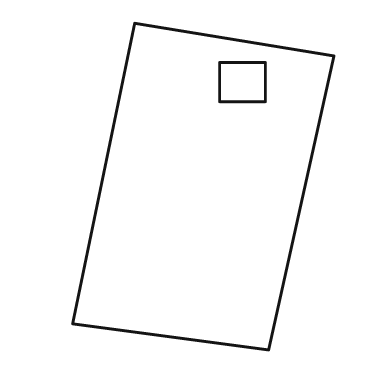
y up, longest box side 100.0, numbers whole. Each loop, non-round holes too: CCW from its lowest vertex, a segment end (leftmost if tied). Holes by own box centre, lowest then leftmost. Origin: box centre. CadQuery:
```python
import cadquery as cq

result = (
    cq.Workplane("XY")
    .moveTo(20.0, -50.0)
    .lineTo(40.0, 40.0)
    .lineTo(-21.0, 50.0)
    .lineTo(-40.0, -42.0)
    .close()
    .moveTo(5.0, 26.0)
    .lineTo(19.0, 26.0)
    .lineTo(19.0, 38.0)
    .lineTo(5.0, 38.0)
    .close()
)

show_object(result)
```